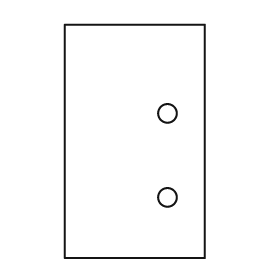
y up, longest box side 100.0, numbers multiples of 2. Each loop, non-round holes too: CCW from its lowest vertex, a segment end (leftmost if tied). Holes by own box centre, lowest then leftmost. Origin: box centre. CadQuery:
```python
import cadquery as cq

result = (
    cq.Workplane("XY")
    .moveTo(-30.0, -50.0)
    .lineTo(30.0, -50.0)
    .lineTo(30.0, 50.0)
    .lineTo(-30.0, 50.0)
    .close()
    .moveTo(14.0, -24.0)
    .circle(4.0)
    .moveTo(14.0, 12.0)
    .circle(4.0)
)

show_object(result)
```